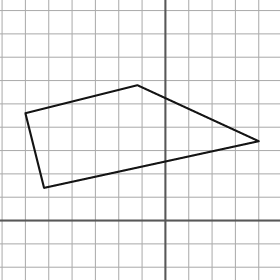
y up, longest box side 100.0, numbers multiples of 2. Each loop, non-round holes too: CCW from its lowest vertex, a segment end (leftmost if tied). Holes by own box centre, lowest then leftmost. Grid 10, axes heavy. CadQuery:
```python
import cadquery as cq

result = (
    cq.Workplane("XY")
    .moveTo(-52.0, 14.0)
    .lineTo(40.0, 34.0)
    .lineTo(-12.0, 58.0)
    .lineTo(-60.0, 46.0)
    .close()
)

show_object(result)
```